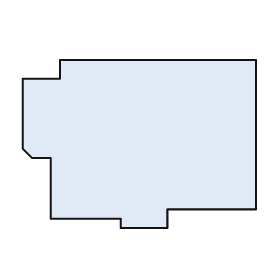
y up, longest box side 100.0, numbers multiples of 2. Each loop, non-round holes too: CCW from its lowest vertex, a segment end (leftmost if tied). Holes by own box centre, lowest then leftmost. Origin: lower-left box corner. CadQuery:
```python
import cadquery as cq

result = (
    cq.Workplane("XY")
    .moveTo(42.0, 0.0)
    .lineTo(62.0, 0.0)
    .lineTo(62.0, 8.0)
    .lineTo(100.0, 8.0)
    .lineTo(100.0, 72.0)
    .lineTo(16.0, 72.0)
    .lineTo(16.0, 64.0)
    .lineTo(0.0, 64.0)
    .lineTo(0.0, 34.0)
    .lineTo(4.0, 30.0)
    .lineTo(12.0, 30.0)
    .lineTo(12.0, 4.0)
    .lineTo(42.0, 4.0)
    .close()
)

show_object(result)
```